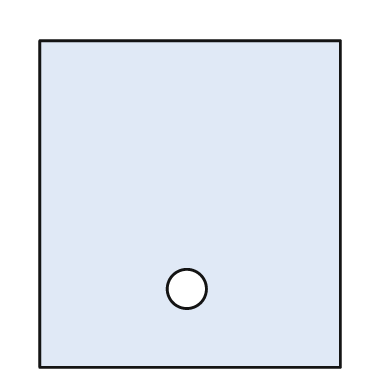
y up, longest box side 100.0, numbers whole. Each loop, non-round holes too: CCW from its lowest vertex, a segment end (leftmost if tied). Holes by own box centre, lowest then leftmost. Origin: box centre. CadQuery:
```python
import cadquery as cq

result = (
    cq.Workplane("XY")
    .moveTo(-46.0, -50.0)
    .lineTo(46.0, -50.0)
    .lineTo(46.0, 50.0)
    .lineTo(-46.0, 50.0)
    .close()
    .moveTo(-1.0, -26.0)
    .circle(6.0)
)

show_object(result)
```